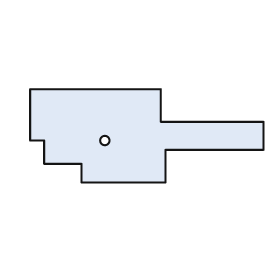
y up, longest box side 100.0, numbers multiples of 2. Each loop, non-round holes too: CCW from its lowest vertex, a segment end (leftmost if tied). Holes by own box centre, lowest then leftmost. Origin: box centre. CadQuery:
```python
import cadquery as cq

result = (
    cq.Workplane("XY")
    .moveTo(-28.0, -20.0)
    .lineTo(8.0, -20.0)
    .lineTo(8.0, -6.0)
    .lineTo(50.0, -6.0)
    .lineTo(50.0, 6.0)
    .lineTo(6.0, 6.0)
    .lineTo(6.0, 20.0)
    .lineTo(-50.0, 20.0)
    .lineTo(-50.0, -2.0)
    .lineTo(-44.0, -2.0)
    .lineTo(-44.0, -12.0)
    .lineTo(-28.0, -12.0)
    .close()
    .moveTo(-18.0, -2.0)
    .circle(2.0)
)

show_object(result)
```